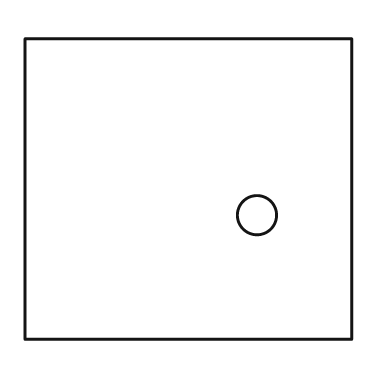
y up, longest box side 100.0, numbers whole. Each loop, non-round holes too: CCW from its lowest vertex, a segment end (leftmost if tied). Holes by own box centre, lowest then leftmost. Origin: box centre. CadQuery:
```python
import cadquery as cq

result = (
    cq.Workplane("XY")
    .moveTo(-50.0, -46.0)
    .lineTo(50.0, -46.0)
    .lineTo(50.0, 46.0)
    .lineTo(-50.0, 46.0)
    .close()
    .moveTo(21.0, -8.0)
    .circle(6.0)
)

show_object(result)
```